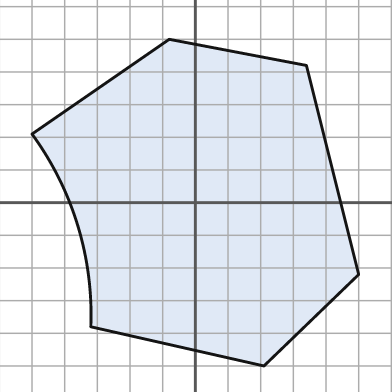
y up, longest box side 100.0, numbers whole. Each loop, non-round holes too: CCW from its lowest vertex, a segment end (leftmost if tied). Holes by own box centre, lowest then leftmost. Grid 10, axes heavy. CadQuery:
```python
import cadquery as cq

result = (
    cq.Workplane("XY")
    .moveTo(21.0, -50.0)
    .lineTo(50.0, -22.0)
    .lineTo(34.0, 42.0)
    .lineTo(-8.0, 50.0)
    .lineTo(-50.0, 21.0)
    .threePointArc((-36.0, -7.0), (-32.0, -38.0))
    .close()
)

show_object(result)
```